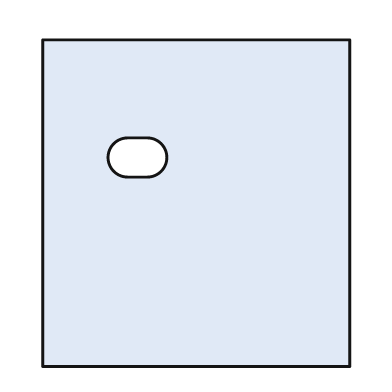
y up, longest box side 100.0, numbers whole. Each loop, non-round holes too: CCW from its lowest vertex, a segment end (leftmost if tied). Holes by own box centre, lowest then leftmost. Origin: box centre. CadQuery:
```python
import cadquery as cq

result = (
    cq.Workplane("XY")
    .moveTo(-47.0, -50.0)
    .lineTo(47.0, -50.0)
    .lineTo(47.0, 50.0)
    .lineTo(-47.0, 50.0)
    .close()
    .moveTo(-21.0, 8.0)
    .lineTo(-15.0, 8.0)
    .threePointArc((-9.0, 14.0), (-15.0, 20.0))
    .lineTo(-21.0, 20.0)
    .threePointArc((-27.0, 14.0), (-21.0, 8.0))
    .close()
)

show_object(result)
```